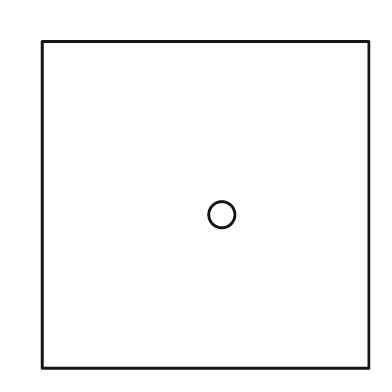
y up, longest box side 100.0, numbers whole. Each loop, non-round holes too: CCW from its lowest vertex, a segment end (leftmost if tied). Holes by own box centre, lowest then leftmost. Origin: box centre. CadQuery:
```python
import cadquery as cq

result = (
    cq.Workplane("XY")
    .moveTo(-50.0, -50.0)
    .lineTo(50.0, -50.0)
    .lineTo(50.0, 50.0)
    .lineTo(-50.0, 50.0)
    .close()
    .moveTo(5.0, -3.0)
    .circle(4.0)
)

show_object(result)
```